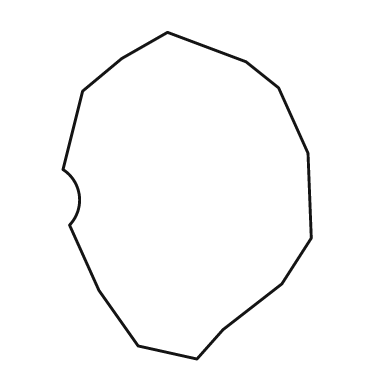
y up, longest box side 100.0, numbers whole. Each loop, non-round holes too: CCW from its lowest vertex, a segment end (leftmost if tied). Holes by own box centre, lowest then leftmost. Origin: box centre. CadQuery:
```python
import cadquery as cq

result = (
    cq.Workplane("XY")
    .moveTo(3.0, -50.0)
    .lineTo(11.0, -41.0)
    .lineTo(29.0, -27.0)
    .lineTo(38.0, -13.0)
    .lineTo(37.0, 13.0)
    .lineTo(28.0, 33.0)
    .lineTo(18.0, 41.0)
    .lineTo(-6.0, 50.0)
    .lineTo(-20.0, 42.0)
    .lineTo(-32.0, 32.0)
    .lineTo(-38.0, 8.0)
    .threePointArc((-33.0, 0.0), (-36.0, -9.0))
    .lineTo(-27.0, -29.0)
    .lineTo(-15.0, -46.0)
    .close()
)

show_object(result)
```